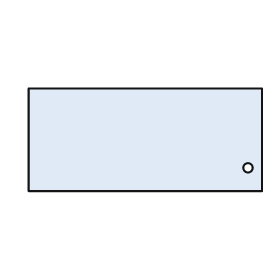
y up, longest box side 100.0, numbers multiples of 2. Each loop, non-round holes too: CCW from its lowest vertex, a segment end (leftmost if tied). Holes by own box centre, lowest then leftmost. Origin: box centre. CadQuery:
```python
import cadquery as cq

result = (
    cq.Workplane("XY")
    .moveTo(-50.0, -22.0)
    .lineTo(50.0, -22.0)
    .lineTo(50.0, 22.0)
    .lineTo(-50.0, 22.0)
    .close()
    .moveTo(44.0, -12.0)
    .circle(2.0)
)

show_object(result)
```